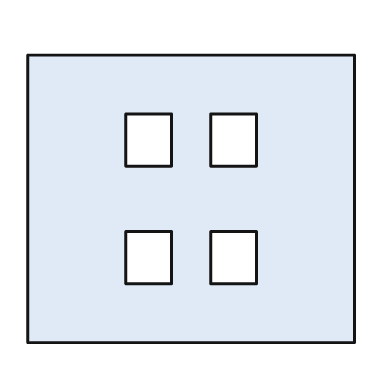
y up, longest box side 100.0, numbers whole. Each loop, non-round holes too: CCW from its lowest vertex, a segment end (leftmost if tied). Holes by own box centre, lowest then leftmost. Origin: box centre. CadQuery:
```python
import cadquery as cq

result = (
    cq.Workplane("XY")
    .moveTo(-50.0, -44.0)
    .lineTo(50.0, -44.0)
    .lineTo(50.0, 44.0)
    .lineTo(-50.0, 44.0)
    .close()
    .moveTo(-20.0, -26.0)
    .lineTo(-6.0, -26.0)
    .lineTo(-6.0, -10.0)
    .lineTo(-20.0, -10.0)
    .close()
    .moveTo(6.0, -26.0)
    .lineTo(20.0, -26.0)
    .lineTo(20.0, -10.0)
    .lineTo(6.0, -10.0)
    .close()
    .moveTo(-20.0, 10.0)
    .lineTo(-6.0, 10.0)
    .lineTo(-6.0, 26.0)
    .lineTo(-20.0, 26.0)
    .close()
    .moveTo(6.0, 10.0)
    .lineTo(20.0, 10.0)
    .lineTo(20.0, 26.0)
    .lineTo(6.0, 26.0)
    .close()
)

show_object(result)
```